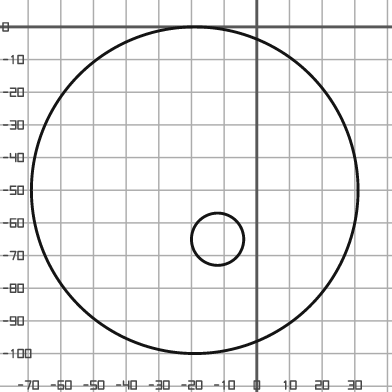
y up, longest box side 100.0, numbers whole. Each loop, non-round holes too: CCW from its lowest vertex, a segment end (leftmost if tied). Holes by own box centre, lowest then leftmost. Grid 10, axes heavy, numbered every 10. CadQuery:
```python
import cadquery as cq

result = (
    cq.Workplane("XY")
    .moveTo(-19.0, -50.0)
    .circle(50.0)
    .moveTo(-12.0, -65.0)
    .circle(8.0)
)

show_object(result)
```